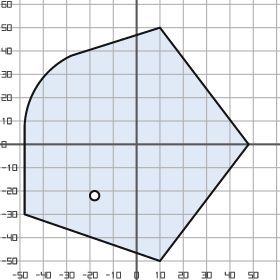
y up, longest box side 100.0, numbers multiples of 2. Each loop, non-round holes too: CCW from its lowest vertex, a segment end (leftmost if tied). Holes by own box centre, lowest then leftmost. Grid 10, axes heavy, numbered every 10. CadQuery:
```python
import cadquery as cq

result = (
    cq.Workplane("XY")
    .moveTo(10.0, -50.0)
    .lineTo(48.0, 0.0)
    .lineTo(10.0, 50.0)
    .lineTo(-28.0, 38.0)
    .threePointArc((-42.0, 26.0), (-48.0, 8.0))
    .lineTo(-48.0, -30.0)
    .close()
    .moveTo(-18.0, -22.0)
    .circle(2.0)
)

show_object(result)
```